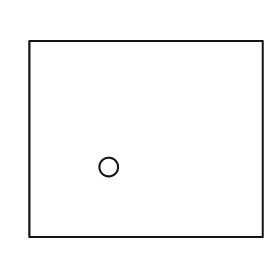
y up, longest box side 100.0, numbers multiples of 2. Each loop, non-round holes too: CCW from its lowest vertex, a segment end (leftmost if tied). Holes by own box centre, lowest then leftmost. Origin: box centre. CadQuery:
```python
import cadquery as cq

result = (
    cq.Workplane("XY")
    .moveTo(-50.0, -42.0)
    .lineTo(50.0, -42.0)
    .lineTo(50.0, 42.0)
    .lineTo(-50.0, 42.0)
    .close()
    .moveTo(-16.0, -12.0)
    .circle(4.0)
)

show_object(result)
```